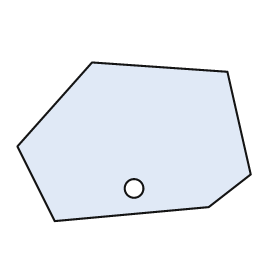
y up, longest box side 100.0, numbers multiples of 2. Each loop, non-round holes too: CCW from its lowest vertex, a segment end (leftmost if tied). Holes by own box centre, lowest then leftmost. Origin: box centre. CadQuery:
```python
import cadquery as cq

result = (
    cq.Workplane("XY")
    .moveTo(-34.0, -34.0)
    .lineTo(32.0, -28.0)
    .lineTo(50.0, -14.0)
    .lineTo(40.0, 30.0)
    .lineTo(-18.0, 34.0)
    .lineTo(-50.0, -2.0)
    .close()
    .moveTo(0.0, -20.0)
    .circle(4.0)
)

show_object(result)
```